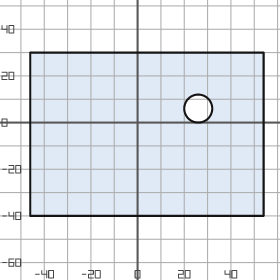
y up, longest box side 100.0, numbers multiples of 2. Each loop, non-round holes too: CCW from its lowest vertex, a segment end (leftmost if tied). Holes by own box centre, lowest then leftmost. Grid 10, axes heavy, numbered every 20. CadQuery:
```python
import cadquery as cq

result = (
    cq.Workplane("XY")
    .moveTo(-46.0, -40.0)
    .lineTo(54.0, -40.0)
    .lineTo(54.0, 30.0)
    .lineTo(-46.0, 30.0)
    .close()
    .moveTo(26.0, 6.0)
    .circle(6.0)
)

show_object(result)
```